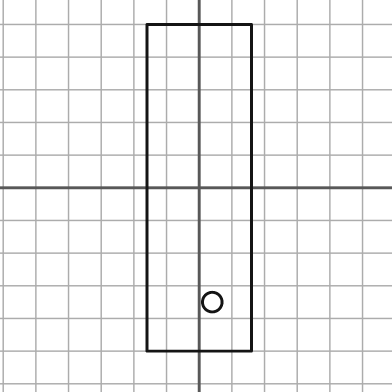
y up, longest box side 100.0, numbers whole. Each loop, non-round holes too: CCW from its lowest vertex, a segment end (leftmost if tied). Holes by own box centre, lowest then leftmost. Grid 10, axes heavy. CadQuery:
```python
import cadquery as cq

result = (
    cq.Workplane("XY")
    .moveTo(-16.0, -50.0)
    .lineTo(16.0, -50.0)
    .lineTo(16.0, 50.0)
    .lineTo(-16.0, 50.0)
    .close()
    .moveTo(4.0, -35.0)
    .circle(3.0)
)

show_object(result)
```